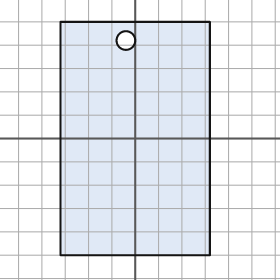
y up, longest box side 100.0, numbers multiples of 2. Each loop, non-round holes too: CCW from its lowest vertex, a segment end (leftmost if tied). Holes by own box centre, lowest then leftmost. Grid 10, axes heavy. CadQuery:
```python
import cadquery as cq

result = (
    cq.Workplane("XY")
    .moveTo(-32.0, -50.0)
    .lineTo(32.0, -50.0)
    .lineTo(32.0, 50.0)
    .lineTo(-32.0, 50.0)
    .close()
    .moveTo(-4.0, 42.0)
    .circle(4.0)
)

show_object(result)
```